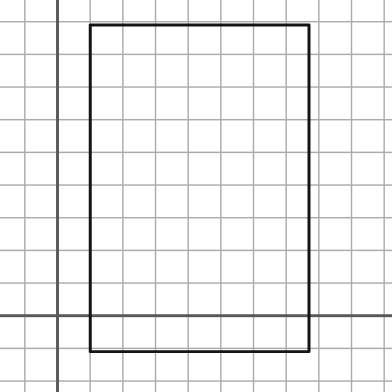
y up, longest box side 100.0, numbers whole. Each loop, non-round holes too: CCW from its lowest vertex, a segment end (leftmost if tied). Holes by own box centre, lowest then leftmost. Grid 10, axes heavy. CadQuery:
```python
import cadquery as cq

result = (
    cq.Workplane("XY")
    .moveTo(10.0, -11.0)
    .lineTo(77.0, -11.0)
    .lineTo(77.0, 89.0)
    .lineTo(10.0, 89.0)
    .close()
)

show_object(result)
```